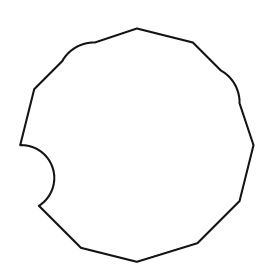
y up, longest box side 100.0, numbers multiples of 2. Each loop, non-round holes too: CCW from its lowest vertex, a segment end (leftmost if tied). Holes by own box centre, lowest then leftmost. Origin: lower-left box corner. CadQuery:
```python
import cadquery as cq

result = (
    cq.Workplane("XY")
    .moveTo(50.0, 0.0)
    .lineTo(76.0, 8.0)
    .lineTo(94.0, 26.0)
    .lineTo(100.0, 50.0)
    .lineTo(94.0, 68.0)
    .threePointArc((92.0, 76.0), (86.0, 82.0))
    .lineTo(74.0, 94.0)
    .lineTo(50.0, 100.0)
    .lineTo(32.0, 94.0)
    .threePointArc((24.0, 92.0), (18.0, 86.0))
    .lineTo(6.0, 74.0)
    .lineTo(0.0, 50.0)
    .threePointArc((14.0, 40.0), (8.0, 24.0))
    .lineTo(26.0, 6.0)
    .close()
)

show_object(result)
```